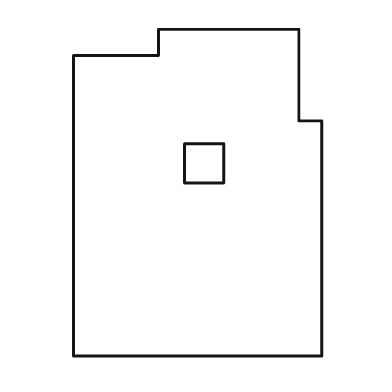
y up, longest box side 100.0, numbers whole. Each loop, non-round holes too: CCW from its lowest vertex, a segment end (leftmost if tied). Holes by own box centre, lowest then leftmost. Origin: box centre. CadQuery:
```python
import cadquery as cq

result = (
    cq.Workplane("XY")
    .moveTo(-38.0, -50.0)
    .lineTo(38.0, -50.0)
    .lineTo(38.0, 22.0)
    .lineTo(31.0, 22.0)
    .lineTo(31.0, 50.0)
    .lineTo(-12.0, 50.0)
    .lineTo(-12.0, 42.0)
    .lineTo(-38.0, 42.0)
    .close()
    .moveTo(-4.0, 3.0)
    .lineTo(8.0, 3.0)
    .lineTo(8.0, 15.0)
    .lineTo(-4.0, 15.0)
    .close()
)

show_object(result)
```